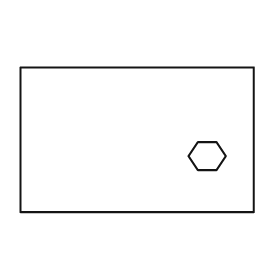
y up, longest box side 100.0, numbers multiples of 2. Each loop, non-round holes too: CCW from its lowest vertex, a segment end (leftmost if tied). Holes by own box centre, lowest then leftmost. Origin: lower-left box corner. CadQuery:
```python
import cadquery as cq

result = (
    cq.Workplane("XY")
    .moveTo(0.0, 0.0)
    .lineTo(100.0, 0.0)
    .lineTo(100.0, 62.0)
    .lineTo(0.0, 62.0)
    .close()
    .moveTo(76.0, 18.0)
    .lineTo(84.0, 18.0)
    .lineTo(88.0, 24.0)
    .lineTo(84.0, 30.0)
    .lineTo(76.0, 30.0)
    .lineTo(72.0, 24.0)
    .close()
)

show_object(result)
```